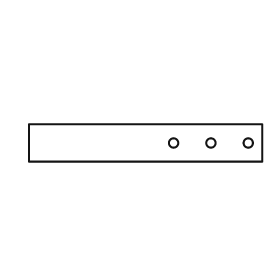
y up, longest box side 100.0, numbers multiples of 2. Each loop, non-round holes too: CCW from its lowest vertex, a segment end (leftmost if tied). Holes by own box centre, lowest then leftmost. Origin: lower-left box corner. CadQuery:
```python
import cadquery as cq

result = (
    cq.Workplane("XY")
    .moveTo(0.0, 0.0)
    .lineTo(100.0, 0.0)
    .lineTo(100.0, 16.0)
    .lineTo(0.0, 16.0)
    .close()
    .moveTo(62.0, 8.0)
    .circle(2.0)
    .moveTo(78.0, 8.0)
    .circle(2.0)
    .moveTo(94.0, 8.0)
    .circle(2.0)
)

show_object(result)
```